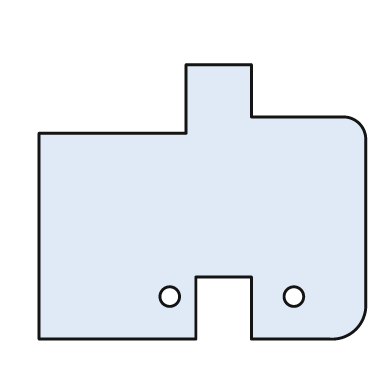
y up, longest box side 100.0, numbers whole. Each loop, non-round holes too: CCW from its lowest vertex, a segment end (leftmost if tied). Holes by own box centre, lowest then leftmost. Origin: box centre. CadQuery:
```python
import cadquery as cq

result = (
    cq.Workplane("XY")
    .moveTo(-50.0, -42.0)
    .lineTo(-2.0, -42.0)
    .lineTo(-2.0, -23.0)
    .lineTo(15.0, -23.0)
    .lineTo(15.0, -42.0)
    .lineTo(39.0, -42.0)
    .threePointArc((47.0, -39.0), (50.0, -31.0))
    .lineTo(50.0, 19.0)
    .threePointArc((48.0, 24.0), (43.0, 26.0))
    .lineTo(15.0, 26.0)
    .lineTo(15.0, 42.0)
    .lineTo(-5.0, 42.0)
    .lineTo(-5.0, 21.0)
    .lineTo(-50.0, 21.0)
    .close()
    .moveTo(-10.0, -29.0)
    .circle(3.0)
    .moveTo(28.0, -29.0)
    .circle(3.0)
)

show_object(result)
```